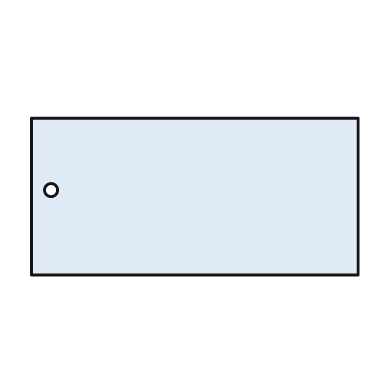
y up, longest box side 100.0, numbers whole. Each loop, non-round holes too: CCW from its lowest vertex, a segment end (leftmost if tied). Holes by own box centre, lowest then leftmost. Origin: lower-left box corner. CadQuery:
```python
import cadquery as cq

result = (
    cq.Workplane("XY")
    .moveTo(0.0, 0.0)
    .lineTo(100.0, 0.0)
    .lineTo(100.0, 48.0)
    .lineTo(0.0, 48.0)
    .close()
    .moveTo(6.0, 26.0)
    .circle(2.0)
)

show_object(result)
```